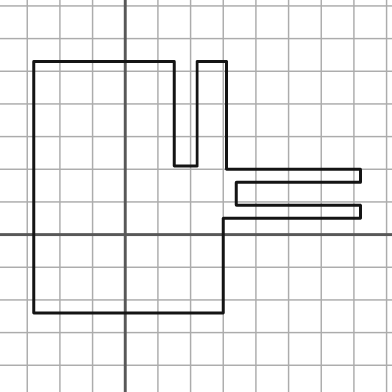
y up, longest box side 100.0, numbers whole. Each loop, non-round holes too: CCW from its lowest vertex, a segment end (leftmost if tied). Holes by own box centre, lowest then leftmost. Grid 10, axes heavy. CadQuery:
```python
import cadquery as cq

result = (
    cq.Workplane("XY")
    .moveTo(-28.0, -24.0)
    .lineTo(30.0, -24.0)
    .lineTo(30.0, 5.0)
    .lineTo(72.0, 5.0)
    .lineTo(72.0, 9.0)
    .lineTo(34.0, 9.0)
    .lineTo(34.0, 16.0)
    .lineTo(72.0, 16.0)
    .lineTo(72.0, 20.0)
    .lineTo(31.0, 20.0)
    .lineTo(31.0, 53.0)
    .lineTo(22.0, 53.0)
    .lineTo(22.0, 21.0)
    .lineTo(15.0, 21.0)
    .lineTo(15.0, 53.0)
    .lineTo(-28.0, 53.0)
    .close()
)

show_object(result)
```